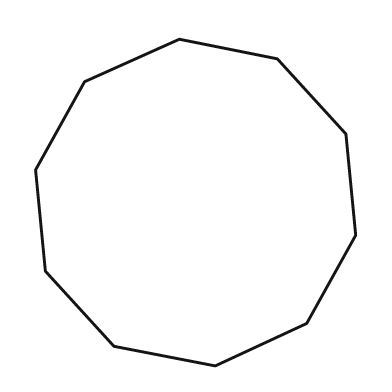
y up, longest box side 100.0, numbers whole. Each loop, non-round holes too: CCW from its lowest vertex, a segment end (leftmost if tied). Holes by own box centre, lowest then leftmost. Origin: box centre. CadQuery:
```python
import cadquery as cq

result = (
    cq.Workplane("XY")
    .moveTo(6.0, -50.0)
    .lineTo(34.0, -37.0)
    .lineTo(49.0, -10.0)
    .lineTo(46.0, 21.0)
    .lineTo(25.0, 44.0)
    .lineTo(-5.0, 50.0)
    .lineTo(-34.0, 37.0)
    .lineTo(-49.0, 10.0)
    .lineTo(-46.0, -21.0)
    .lineTo(-25.0, -44.0)
    .close()
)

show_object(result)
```